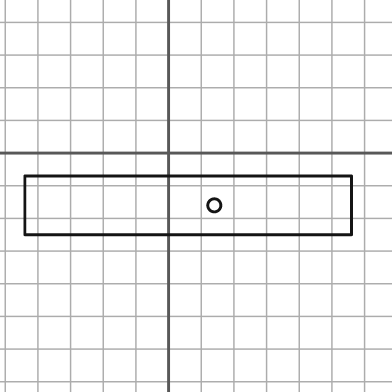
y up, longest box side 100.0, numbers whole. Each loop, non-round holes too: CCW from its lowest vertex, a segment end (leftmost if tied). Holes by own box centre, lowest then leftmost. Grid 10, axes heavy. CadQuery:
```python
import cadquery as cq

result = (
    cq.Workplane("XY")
    .moveTo(-44.0, -25.0)
    .lineTo(56.0, -25.0)
    .lineTo(56.0, -7.0)
    .lineTo(-44.0, -7.0)
    .close()
    .moveTo(14.0, -16.0)
    .circle(2.0)
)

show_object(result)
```